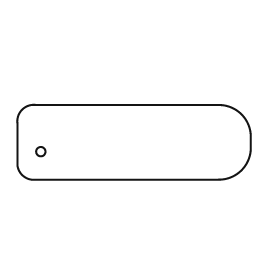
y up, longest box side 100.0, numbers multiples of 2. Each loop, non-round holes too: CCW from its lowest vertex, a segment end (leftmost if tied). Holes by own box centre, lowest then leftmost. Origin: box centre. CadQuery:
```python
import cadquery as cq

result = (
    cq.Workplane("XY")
    .moveTo(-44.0, -16.0)
    .lineTo(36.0, -16.0)
    .threePointArc((46.0, -12.0), (50.0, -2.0))
    .lineTo(50.0, 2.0)
    .threePointArc((46.0, 12.0), (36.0, 16.0))
    .lineTo(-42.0, 16.0)
    .threePointArc((-48.0, 14.0), (-50.0, 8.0))
    .lineTo(-50.0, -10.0)
    .threePointArc((-48.0, -14.0), (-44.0, -16.0))
    .close()
    .moveTo(-40.0, -4.0)
    .circle(2.0)
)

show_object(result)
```